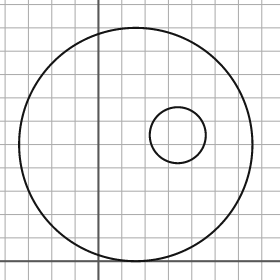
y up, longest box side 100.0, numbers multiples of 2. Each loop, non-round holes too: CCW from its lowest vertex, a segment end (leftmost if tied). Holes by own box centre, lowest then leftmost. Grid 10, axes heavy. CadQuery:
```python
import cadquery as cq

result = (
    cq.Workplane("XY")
    .moveTo(16.0, 50.0)
    .circle(50.0)
    .moveTo(34.0, 54.0)
    .circle(12.0)
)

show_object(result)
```